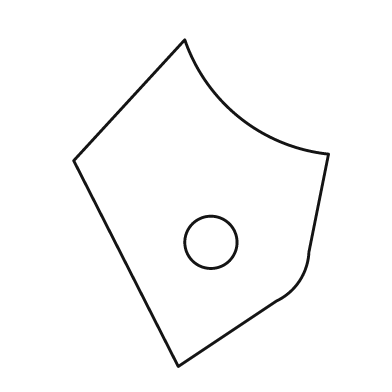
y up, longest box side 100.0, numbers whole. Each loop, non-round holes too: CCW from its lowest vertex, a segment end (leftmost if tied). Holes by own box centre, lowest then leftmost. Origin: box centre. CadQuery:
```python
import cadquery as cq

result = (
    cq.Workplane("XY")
    .moveTo(-7.0, -50.0)
    .lineTo(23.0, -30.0)
    .threePointArc((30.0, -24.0), (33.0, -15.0))
    .lineTo(39.0, 15.0)
    .threePointArc((12.0, 26.0), (-5.0, 50.0))
    .lineTo(-39.0, 13.0)
    .close()
    .moveTo(3.0, -12.0)
    .circle(8.0)
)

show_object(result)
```